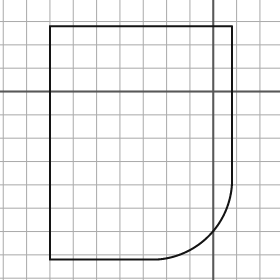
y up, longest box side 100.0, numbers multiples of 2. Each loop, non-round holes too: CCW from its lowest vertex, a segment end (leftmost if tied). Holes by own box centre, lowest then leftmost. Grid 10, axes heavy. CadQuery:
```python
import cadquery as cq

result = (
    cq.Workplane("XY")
    .moveTo(-70.0, -72.0)
    .lineTo(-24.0, -72.0)
    .threePointArc((-2.0, -62.0), (8.0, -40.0))
    .lineTo(8.0, 28.0)
    .lineTo(-70.0, 28.0)
    .close()
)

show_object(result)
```